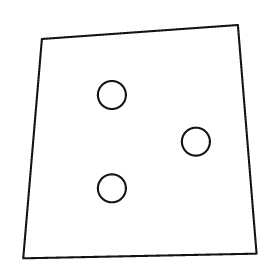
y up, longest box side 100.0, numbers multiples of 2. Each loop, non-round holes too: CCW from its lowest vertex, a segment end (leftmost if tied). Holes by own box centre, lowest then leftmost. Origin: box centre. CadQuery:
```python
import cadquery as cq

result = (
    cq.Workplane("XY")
    .moveTo(-50.0, -50.0)
    .lineTo(50.0, -48.0)
    .lineTo(42.0, 50.0)
    .lineTo(-42.0, 44.0)
    .close()
    .moveTo(-12.0, -20.0)
    .circle(6.0)
    .moveTo(24.0, 0.0)
    .circle(6.0)
    .moveTo(-12.0, 20.0)
    .circle(6.0)
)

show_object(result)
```